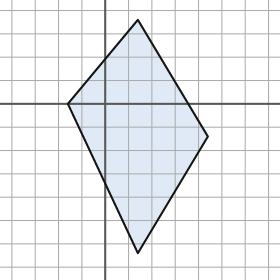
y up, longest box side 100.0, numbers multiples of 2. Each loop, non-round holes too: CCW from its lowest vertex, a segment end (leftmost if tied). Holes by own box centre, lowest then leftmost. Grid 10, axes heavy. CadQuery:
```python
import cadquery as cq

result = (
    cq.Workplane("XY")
    .moveTo(14.0, -64.0)
    .lineTo(44.0, -14.0)
    .lineTo(14.0, 36.0)
    .lineTo(-16.0, 0.0)
    .close()
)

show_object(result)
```